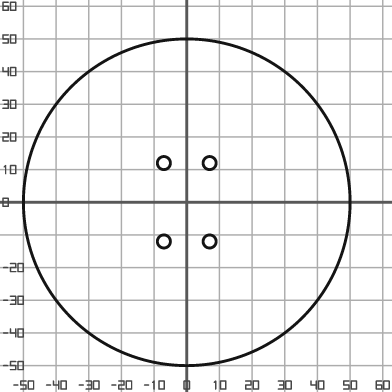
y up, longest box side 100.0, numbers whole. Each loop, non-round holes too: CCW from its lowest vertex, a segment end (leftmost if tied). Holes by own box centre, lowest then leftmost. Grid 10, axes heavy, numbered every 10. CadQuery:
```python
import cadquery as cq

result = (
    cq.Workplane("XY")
    .moveTo(0.0, 0.0)
    .circle(50.0)
    .moveTo(-7.0, -12.0)
    .circle(2.0)
    .moveTo(7.0, -12.0)
    .circle(2.0)
    .moveTo(-7.0, 12.0)
    .circle(2.0)
    .moveTo(7.0, 12.0)
    .circle(2.0)
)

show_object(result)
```